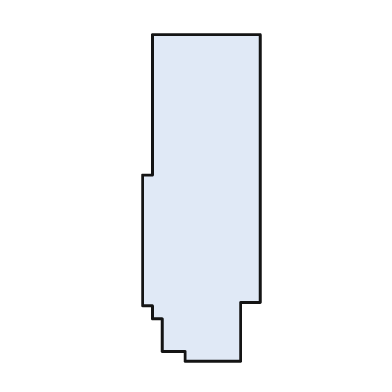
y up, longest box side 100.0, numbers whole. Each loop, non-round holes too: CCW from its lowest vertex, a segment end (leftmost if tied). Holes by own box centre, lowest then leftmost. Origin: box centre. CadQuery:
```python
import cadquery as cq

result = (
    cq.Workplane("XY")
    .moveTo(-5.0, -50.0)
    .lineTo(12.0, -50.0)
    .lineTo(12.0, -32.0)
    .lineTo(18.0, -32.0)
    .lineTo(18.0, 50.0)
    .lineTo(-15.0, 50.0)
    .lineTo(-15.0, 7.0)
    .lineTo(-18.0, 7.0)
    .lineTo(-18.0, -33.0)
    .lineTo(-15.0, -33.0)
    .lineTo(-15.0, -37.0)
    .lineTo(-12.0, -37.0)
    .lineTo(-12.0, -47.0)
    .lineTo(-5.0, -47.0)
    .close()
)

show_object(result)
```